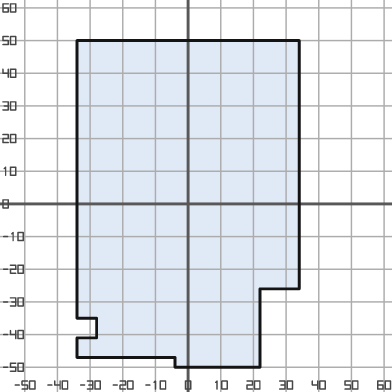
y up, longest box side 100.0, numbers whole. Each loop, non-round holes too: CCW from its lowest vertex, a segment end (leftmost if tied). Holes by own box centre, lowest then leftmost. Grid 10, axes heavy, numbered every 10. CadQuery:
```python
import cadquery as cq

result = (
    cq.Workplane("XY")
    .moveTo(-4.0, -50.0)
    .lineTo(22.0, -50.0)
    .lineTo(22.0, -26.0)
    .lineTo(34.0, -26.0)
    .lineTo(34.0, 50.0)
    .lineTo(-34.0, 50.0)
    .lineTo(-34.0, -35.0)
    .lineTo(-28.0, -35.0)
    .lineTo(-28.0, -41.0)
    .lineTo(-34.0, -41.0)
    .lineTo(-34.0, -47.0)
    .lineTo(-4.0, -47.0)
    .close()
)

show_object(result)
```